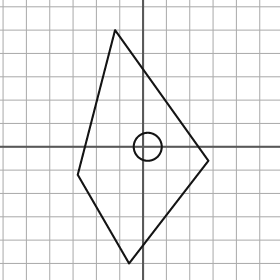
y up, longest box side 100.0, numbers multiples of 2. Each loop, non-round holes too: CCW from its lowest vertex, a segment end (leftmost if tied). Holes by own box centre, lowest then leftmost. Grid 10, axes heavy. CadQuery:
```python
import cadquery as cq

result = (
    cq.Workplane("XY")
    .moveTo(-6.0, -50.0)
    .lineTo(28.0, -6.0)
    .lineTo(-12.0, 50.0)
    .lineTo(-28.0, -12.0)
    .close()
    .moveTo(2.0, 0.0)
    .circle(6.0)
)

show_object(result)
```